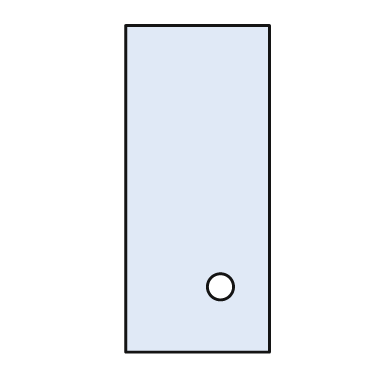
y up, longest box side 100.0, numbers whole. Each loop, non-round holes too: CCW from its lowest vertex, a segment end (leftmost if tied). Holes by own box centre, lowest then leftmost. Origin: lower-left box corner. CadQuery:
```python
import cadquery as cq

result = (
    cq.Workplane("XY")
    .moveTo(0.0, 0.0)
    .lineTo(44.0, 0.0)
    .lineTo(44.0, 100.0)
    .lineTo(0.0, 100.0)
    .close()
    .moveTo(29.0, 20.0)
    .circle(4.0)
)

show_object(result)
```